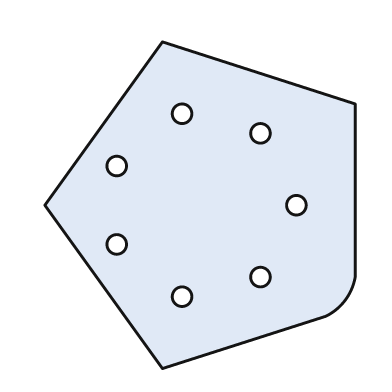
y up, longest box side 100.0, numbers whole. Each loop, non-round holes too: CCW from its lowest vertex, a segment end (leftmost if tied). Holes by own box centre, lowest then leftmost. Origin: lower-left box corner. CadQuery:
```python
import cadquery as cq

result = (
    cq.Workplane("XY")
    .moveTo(36.0, 0.0)
    .lineTo(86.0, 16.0)
    .threePointArc((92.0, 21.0), (95.0, 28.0))
    .lineTo(95.0, 81.0)
    .lineTo(36.0, 100.0)
    .lineTo(0.0, 50.0)
    .close()
    .moveTo(42.0, 22.0)
    .circle(3.0)
    .moveTo(66.0, 28.0)
    .circle(3.0)
    .moveTo(22.0, 38.0)
    .circle(3.0)
    .moveTo(77.0, 50.0)
    .circle(3.0)
    .moveTo(22.0, 62.0)
    .circle(3.0)
    .moveTo(66.0, 72.0)
    .circle(3.0)
    .moveTo(42.0, 78.0)
    .circle(3.0)
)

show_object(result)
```